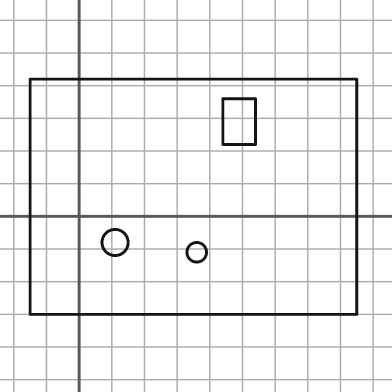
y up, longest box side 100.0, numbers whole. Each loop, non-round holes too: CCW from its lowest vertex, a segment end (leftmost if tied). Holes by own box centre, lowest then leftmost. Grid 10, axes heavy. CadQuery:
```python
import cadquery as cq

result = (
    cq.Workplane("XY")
    .moveTo(-15.0, -30.0)
    .lineTo(85.0, -30.0)
    .lineTo(85.0, 42.0)
    .lineTo(-15.0, 42.0)
    .close()
    .moveTo(36.0, -11.0)
    .circle(3.0)
    .moveTo(11.0, -8.0)
    .circle(4.0)
    .moveTo(44.0, 22.0)
    .lineTo(54.0, 22.0)
    .lineTo(54.0, 36.0)
    .lineTo(44.0, 36.0)
    .close()
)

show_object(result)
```